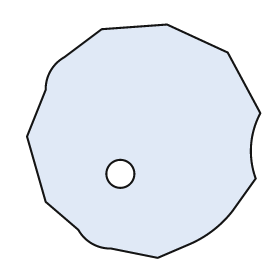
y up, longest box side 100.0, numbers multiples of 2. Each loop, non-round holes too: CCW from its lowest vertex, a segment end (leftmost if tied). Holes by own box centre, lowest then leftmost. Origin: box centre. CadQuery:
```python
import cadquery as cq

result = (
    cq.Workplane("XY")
    .moveTo(6.0, -50.0)
    .lineTo(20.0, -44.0)
    .threePointArc((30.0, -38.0), (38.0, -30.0))
    .lineTo(48.0, -16.0)
    .threePointArc((46.0, -2.0), (50.0, 12.0))
    .lineTo(36.0, 38.0)
    .lineTo(10.0, 50.0)
    .lineTo(-18.0, 48.0)
    .lineTo(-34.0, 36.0)
    .threePointArc((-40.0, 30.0), (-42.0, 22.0))
    .lineTo(-50.0, 2.0)
    .lineTo(-42.0, -26.0)
    .lineTo(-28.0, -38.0)
    .threePointArc((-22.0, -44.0), (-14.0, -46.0))
    .close()
    .moveTo(-10.0, -14.0)
    .circle(6.0)
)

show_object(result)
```